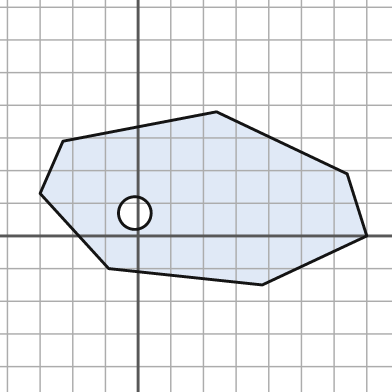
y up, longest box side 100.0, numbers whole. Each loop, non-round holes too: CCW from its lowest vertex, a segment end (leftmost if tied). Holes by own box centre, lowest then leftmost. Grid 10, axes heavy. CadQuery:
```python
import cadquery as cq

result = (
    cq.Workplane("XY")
    .moveTo(38.0, -15.0)
    .lineTo(70.0, 0.0)
    .lineTo(64.0, 19.0)
    .lineTo(24.0, 38.0)
    .lineTo(-23.0, 29.0)
    .lineTo(-30.0, 13.0)
    .lineTo(-9.0, -10.0)
    .close()
    .moveTo(-1.0, 7.0)
    .circle(5.0)
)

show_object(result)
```